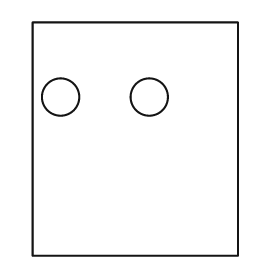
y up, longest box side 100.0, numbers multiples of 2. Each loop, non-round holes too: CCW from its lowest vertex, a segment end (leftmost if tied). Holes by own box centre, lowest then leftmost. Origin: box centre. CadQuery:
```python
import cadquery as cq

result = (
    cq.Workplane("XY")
    .moveTo(-44.0, -50.0)
    .lineTo(44.0, -50.0)
    .lineTo(44.0, 50.0)
    .lineTo(-44.0, 50.0)
    .close()
    .moveTo(-32.0, 18.0)
    .circle(8.0)
    .moveTo(6.0, 18.0)
    .circle(8.0)
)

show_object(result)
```